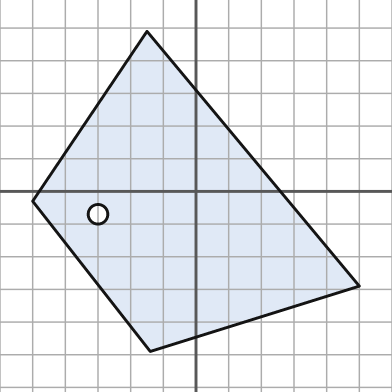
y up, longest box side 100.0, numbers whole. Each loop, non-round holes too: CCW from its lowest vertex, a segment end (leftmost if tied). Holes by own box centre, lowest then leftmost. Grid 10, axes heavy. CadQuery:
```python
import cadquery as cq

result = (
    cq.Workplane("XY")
    .moveTo(-14.0, -49.0)
    .lineTo(50.0, -29.0)
    .lineTo(-15.0, 49.0)
    .lineTo(-50.0, -3.0)
    .close()
    .moveTo(-30.0, -7.0)
    .circle(3.0)
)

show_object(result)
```